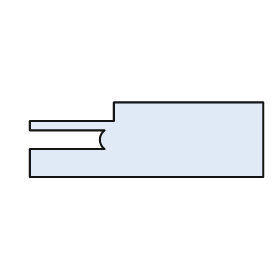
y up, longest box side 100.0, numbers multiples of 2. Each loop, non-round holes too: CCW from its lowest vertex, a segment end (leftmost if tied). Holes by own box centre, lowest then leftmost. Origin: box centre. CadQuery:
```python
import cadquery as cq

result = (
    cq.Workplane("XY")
    .moveTo(-50.0, -16.0)
    .lineTo(50.0, -16.0)
    .lineTo(50.0, 16.0)
    .lineTo(-14.0, 16.0)
    .lineTo(-14.0, 8.0)
    .lineTo(-50.0, 8.0)
    .lineTo(-50.0, 4.0)
    .lineTo(-18.0, 4.0)
    .threePointArc((-20.0, 0.0), (-18.0, -4.0))
    .lineTo(-50.0, -4.0)
    .close()
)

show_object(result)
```